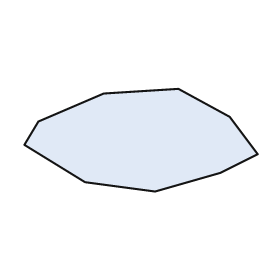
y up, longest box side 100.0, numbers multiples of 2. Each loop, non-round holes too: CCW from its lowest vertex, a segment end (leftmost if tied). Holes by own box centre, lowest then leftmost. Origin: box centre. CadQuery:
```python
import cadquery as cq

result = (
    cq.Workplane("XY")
    .moveTo(6.0, -22.0)
    .lineTo(34.0, -14.0)
    .lineTo(50.0, -6.0)
    .lineTo(38.0, 10.0)
    .lineTo(16.0, 22.0)
    .lineTo(-16.0, 20.0)
    .lineTo(-44.0, 8.0)
    .lineTo(-50.0, -2.0)
    .lineTo(-24.0, -18.0)
    .close()
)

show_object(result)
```